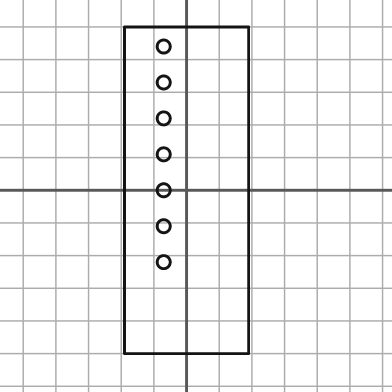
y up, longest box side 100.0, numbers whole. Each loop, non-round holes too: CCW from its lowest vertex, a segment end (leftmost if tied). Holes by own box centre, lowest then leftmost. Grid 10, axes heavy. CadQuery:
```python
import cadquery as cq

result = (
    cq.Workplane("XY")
    .moveTo(-19.0, -50.0)
    .lineTo(19.0, -50.0)
    .lineTo(19.0, 50.0)
    .lineTo(-19.0, 50.0)
    .close()
    .moveTo(-7.0, -22.0)
    .circle(2.0)
    .moveTo(-7.0, -11.0)
    .circle(2.0)
    .moveTo(-7.0, 0.0)
    .circle(2.0)
    .moveTo(-7.0, 11.0)
    .circle(2.0)
    .moveTo(-7.0, 22.0)
    .circle(2.0)
    .moveTo(-7.0, 33.0)
    .circle(2.0)
    .moveTo(-7.0, 44.0)
    .circle(2.0)
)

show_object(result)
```